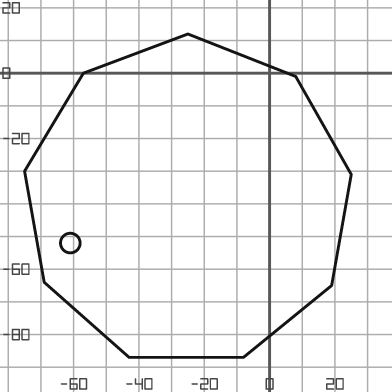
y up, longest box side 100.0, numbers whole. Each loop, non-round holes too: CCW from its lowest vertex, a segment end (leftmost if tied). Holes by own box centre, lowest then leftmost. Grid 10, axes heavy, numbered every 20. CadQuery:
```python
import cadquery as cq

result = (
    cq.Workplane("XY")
    .moveTo(-43.0, -87.0)
    .lineTo(-8.0, -87.0)
    .lineTo(19.0, -65.0)
    .lineTo(25.0, -31.0)
    .lineTo(8.0, -1.0)
    .lineTo(-25.0, 12.0)
    .lineTo(-57.0, 0.0)
    .lineTo(-75.0, -30.0)
    .lineTo(-69.0, -64.0)
    .close()
    .moveTo(-61.0, -52.0)
    .circle(3.0)
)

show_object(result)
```